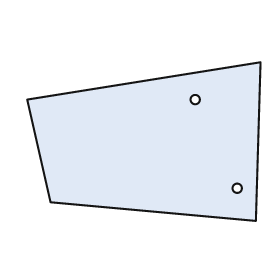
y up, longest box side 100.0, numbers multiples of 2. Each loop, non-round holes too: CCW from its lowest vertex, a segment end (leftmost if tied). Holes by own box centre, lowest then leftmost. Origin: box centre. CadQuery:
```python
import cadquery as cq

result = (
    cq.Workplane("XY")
    .moveTo(48.0, -34.0)
    .lineTo(50.0, 34.0)
    .lineTo(-50.0, 18.0)
    .lineTo(-40.0, -26.0)
    .close()
    .moveTo(40.0, -20.0)
    .circle(2.0)
    .moveTo(22.0, 18.0)
    .circle(2.0)
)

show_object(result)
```